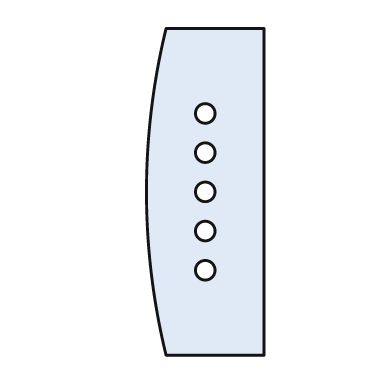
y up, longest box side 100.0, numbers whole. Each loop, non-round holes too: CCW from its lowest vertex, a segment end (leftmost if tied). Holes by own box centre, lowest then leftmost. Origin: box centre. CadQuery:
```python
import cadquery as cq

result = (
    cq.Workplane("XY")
    .moveTo(-12.0, -50.0)
    .lineTo(18.0, -50.0)
    .lineTo(18.0, 50.0)
    .lineTo(-12.0, 50.0)
    .threePointArc((-18.0, 0.0), (-12.0, -50.0))
    .close()
    .moveTo(0.0, -24.0)
    .circle(3.0)
    .moveTo(0.0, -12.0)
    .circle(3.0)
    .moveTo(0.0, 0.0)
    .circle(3.0)
    .moveTo(0.0, 12.0)
    .circle(3.0)
    .moveTo(0.0, 24.0)
    .circle(3.0)
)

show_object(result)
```